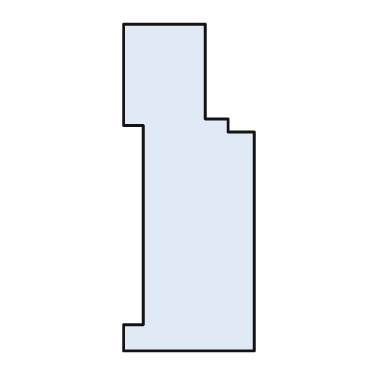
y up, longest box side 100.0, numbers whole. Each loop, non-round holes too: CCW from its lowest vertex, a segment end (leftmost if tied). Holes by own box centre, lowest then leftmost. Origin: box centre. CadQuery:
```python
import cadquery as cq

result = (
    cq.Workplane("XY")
    .moveTo(-20.0, -50.0)
    .lineTo(20.0, -50.0)
    .lineTo(20.0, 17.0)
    .lineTo(12.0, 17.0)
    .lineTo(12.0, 21.0)
    .lineTo(5.0, 21.0)
    .lineTo(5.0, 50.0)
    .lineTo(-20.0, 50.0)
    .lineTo(-20.0, 19.0)
    .lineTo(-14.0, 19.0)
    .lineTo(-14.0, -42.0)
    .lineTo(-20.0, -42.0)
    .close()
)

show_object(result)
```